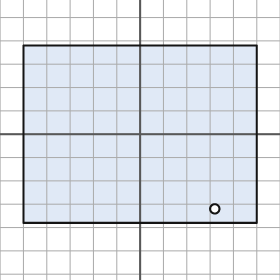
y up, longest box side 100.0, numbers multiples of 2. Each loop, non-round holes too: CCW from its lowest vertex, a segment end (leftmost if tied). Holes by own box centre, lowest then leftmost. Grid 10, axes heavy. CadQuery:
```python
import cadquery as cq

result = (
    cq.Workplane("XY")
    .moveTo(-50.0, -38.0)
    .lineTo(50.0, -38.0)
    .lineTo(50.0, 38.0)
    .lineTo(-50.0, 38.0)
    .close()
    .moveTo(32.0, -32.0)
    .circle(2.0)
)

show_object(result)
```